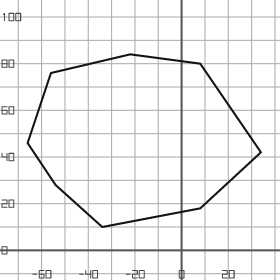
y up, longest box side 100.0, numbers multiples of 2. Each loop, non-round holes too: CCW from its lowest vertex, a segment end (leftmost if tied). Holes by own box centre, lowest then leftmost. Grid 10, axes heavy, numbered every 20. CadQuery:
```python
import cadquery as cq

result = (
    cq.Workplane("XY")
    .moveTo(-34.0, 10.0)
    .lineTo(8.0, 18.0)
    .lineTo(34.0, 42.0)
    .lineTo(8.0, 80.0)
    .lineTo(-22.0, 84.0)
    .lineTo(-56.0, 76.0)
    .lineTo(-66.0, 46.0)
    .lineTo(-54.0, 28.0)
    .close()
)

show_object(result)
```